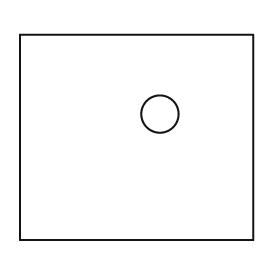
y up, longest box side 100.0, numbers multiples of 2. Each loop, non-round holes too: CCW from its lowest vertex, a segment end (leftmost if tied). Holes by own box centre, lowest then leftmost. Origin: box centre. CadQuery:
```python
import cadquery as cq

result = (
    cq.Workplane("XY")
    .moveTo(-50.0, -44.0)
    .lineTo(50.0, -44.0)
    .lineTo(50.0, 44.0)
    .lineTo(-50.0, 44.0)
    .close()
    .moveTo(10.0, 10.0)
    .circle(8.0)
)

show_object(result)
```